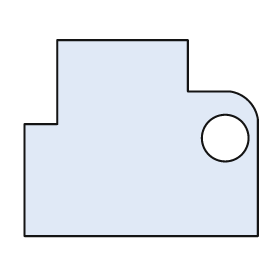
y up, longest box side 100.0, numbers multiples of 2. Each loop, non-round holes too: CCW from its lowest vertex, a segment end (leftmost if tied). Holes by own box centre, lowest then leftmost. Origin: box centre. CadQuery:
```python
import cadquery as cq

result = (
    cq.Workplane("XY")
    .moveTo(-50.0, -42.0)
    .lineTo(50.0, -42.0)
    .lineTo(50.0, 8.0)
    .threePointArc((46.0, 16.0), (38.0, 20.0))
    .lineTo(20.0, 20.0)
    .lineTo(20.0, 42.0)
    .lineTo(-36.0, 42.0)
    .lineTo(-36.0, 6.0)
    .lineTo(-50.0, 6.0)
    .close()
    .moveTo(36.0, 0.0)
    .circle(10.0)
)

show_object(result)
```